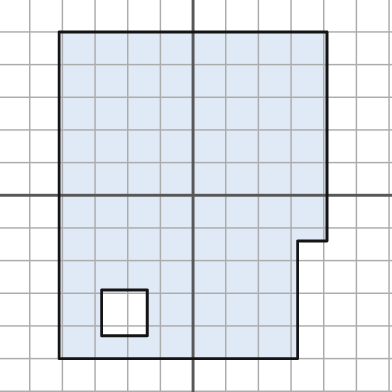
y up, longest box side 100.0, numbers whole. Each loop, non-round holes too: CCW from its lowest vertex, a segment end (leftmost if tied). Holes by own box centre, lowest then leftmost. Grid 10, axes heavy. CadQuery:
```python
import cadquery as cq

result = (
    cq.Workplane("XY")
    .moveTo(-41.0, -50.0)
    .lineTo(32.0, -50.0)
    .lineTo(32.0, -14.0)
    .lineTo(41.0, -14.0)
    .lineTo(41.0, 50.0)
    .lineTo(-41.0, 50.0)
    .close()
    .moveTo(-28.0, -43.0)
    .lineTo(-14.0, -43.0)
    .lineTo(-14.0, -29.0)
    .lineTo(-28.0, -29.0)
    .close()
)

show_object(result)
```